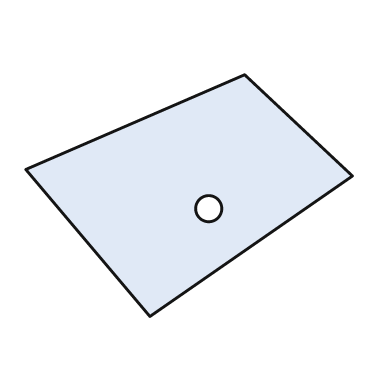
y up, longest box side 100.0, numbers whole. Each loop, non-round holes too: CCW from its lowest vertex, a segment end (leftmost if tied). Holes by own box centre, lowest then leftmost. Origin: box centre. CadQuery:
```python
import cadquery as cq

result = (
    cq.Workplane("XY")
    .moveTo(-12.0, -37.0)
    .lineTo(50.0, 6.0)
    .lineTo(17.0, 37.0)
    .lineTo(-50.0, 8.0)
    .close()
    .moveTo(6.0, -4.0)
    .circle(4.0)
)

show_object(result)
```